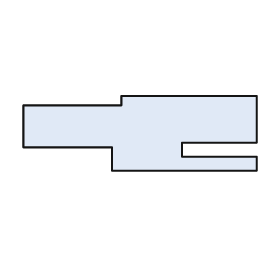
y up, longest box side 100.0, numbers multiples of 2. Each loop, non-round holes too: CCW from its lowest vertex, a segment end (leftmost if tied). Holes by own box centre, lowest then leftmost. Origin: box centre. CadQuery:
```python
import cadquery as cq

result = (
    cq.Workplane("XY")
    .moveTo(-12.0, -16.0)
    .lineTo(50.0, -16.0)
    .lineTo(50.0, -10.0)
    .lineTo(18.0, -10.0)
    .lineTo(18.0, -4.0)
    .lineTo(50.0, -4.0)
    .lineTo(50.0, 16.0)
    .lineTo(-8.0, 16.0)
    .lineTo(-8.0, 12.0)
    .lineTo(-50.0, 12.0)
    .lineTo(-50.0, -6.0)
    .lineTo(-12.0, -6.0)
    .close()
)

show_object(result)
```